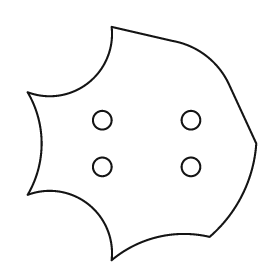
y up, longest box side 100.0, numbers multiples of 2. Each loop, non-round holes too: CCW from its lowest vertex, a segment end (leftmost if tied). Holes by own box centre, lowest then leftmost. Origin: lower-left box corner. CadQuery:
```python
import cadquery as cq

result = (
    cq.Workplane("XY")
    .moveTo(36.0, 0.0)
    .threePointArc((56.0, 10.0), (78.0, 10.0))
    .threePointArc((92.0, 28.0), (98.0, 50.0))
    .lineTo(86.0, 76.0)
    .threePointArc((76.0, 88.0), (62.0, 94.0))
    .lineTo(36.0, 100.0)
    .threePointArc((26.0, 76.0), (0.0, 72.0))
    .threePointArc((6.0, 50.0), (0.0, 28.0))
    .threePointArc((26.0, 24.0), (36.0, 0.0))
    .close()
    .moveTo(32.0, 40.0)
    .circle(4.0)
    .moveTo(70.0, 40.0)
    .circle(4.0)
    .moveTo(32.0, 60.0)
    .circle(4.0)
    .moveTo(70.0, 60.0)
    .circle(4.0)
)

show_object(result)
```